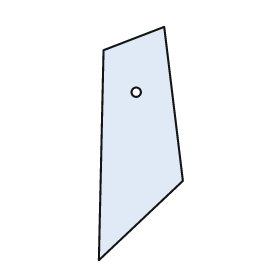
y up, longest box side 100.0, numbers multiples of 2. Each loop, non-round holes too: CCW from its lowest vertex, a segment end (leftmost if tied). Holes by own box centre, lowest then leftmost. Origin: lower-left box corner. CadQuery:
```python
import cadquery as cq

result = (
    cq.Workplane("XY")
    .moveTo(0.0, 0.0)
    .lineTo(36.0, 34.0)
    .lineTo(28.0, 100.0)
    .lineTo(2.0, 90.0)
    .close()
    .moveTo(16.0, 72.0)
    .circle(2.0)
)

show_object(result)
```